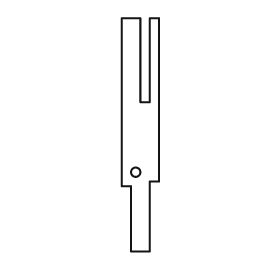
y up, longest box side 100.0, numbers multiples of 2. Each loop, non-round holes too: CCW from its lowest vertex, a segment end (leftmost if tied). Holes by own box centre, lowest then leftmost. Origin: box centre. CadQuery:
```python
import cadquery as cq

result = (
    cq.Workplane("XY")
    .moveTo(-4.0, -50.0)
    .lineTo(4.0, -50.0)
    .lineTo(4.0, -20.0)
    .lineTo(8.0, -20.0)
    .lineTo(8.0, 50.0)
    .lineTo(4.0, 50.0)
    .lineTo(4.0, 14.0)
    .lineTo(0.0, 14.0)
    .lineTo(0.0, 50.0)
    .lineTo(-8.0, 50.0)
    .lineTo(-8.0, -22.0)
    .lineTo(-4.0, -22.0)
    .close()
    .moveTo(-2.0, -16.0)
    .circle(2.0)
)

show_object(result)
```